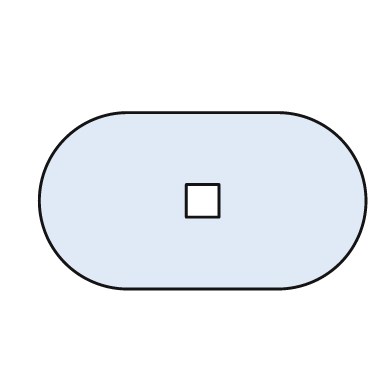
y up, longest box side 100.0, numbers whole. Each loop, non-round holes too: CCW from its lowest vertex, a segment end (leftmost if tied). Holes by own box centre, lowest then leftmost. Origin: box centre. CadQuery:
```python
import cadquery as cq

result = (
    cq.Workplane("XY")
    .moveTo(-23.0, -27.0)
    .lineTo(23.0, -27.0)
    .threePointArc((50.0, 0.0), (23.0, 27.0))
    .lineTo(-23.0, 27.0)
    .threePointArc((-50.0, 0.0), (-23.0, -27.0))
    .close()
    .moveTo(-5.0, -5.0)
    .lineTo(5.0, -5.0)
    .lineTo(5.0, 5.0)
    .lineTo(-5.0, 5.0)
    .close()
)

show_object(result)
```